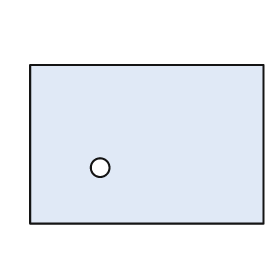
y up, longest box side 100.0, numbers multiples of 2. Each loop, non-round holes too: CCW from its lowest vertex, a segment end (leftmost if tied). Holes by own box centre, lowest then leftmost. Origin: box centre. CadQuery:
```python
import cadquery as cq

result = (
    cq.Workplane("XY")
    .moveTo(-50.0, -34.0)
    .lineTo(50.0, -34.0)
    .lineTo(50.0, 34.0)
    .lineTo(-50.0, 34.0)
    .close()
    .moveTo(-20.0, -10.0)
    .circle(4.0)
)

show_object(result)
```